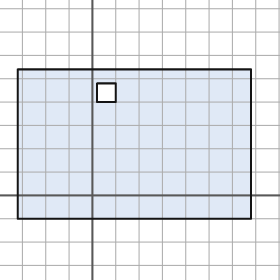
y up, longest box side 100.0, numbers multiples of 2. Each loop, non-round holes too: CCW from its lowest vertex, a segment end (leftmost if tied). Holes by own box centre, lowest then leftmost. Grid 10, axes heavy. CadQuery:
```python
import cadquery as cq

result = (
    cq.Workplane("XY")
    .moveTo(-32.0, -10.0)
    .lineTo(68.0, -10.0)
    .lineTo(68.0, 54.0)
    .lineTo(-32.0, 54.0)
    .close()
    .moveTo(2.0, 40.0)
    .lineTo(10.0, 40.0)
    .lineTo(10.0, 48.0)
    .lineTo(2.0, 48.0)
    .close()
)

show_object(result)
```